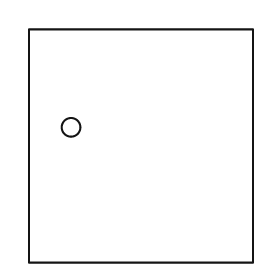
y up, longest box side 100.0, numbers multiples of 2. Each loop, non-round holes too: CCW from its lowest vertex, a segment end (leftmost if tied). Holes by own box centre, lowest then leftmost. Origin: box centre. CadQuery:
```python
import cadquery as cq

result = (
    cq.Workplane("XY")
    .moveTo(-48.0, -50.0)
    .lineTo(48.0, -50.0)
    .lineTo(48.0, 50.0)
    .lineTo(-48.0, 50.0)
    .close()
    .moveTo(-30.0, 8.0)
    .circle(4.0)
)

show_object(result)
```